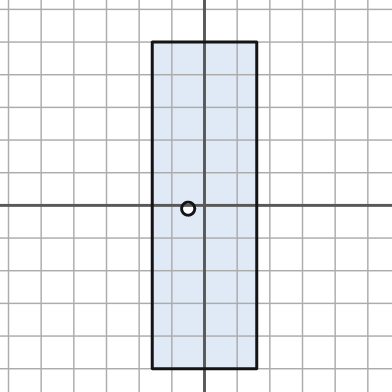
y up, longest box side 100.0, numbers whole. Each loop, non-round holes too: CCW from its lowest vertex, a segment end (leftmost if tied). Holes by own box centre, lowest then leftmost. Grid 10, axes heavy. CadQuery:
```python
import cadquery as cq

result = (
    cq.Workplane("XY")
    .moveTo(-16.0, -50.0)
    .lineTo(16.0, -50.0)
    .lineTo(16.0, 50.0)
    .lineTo(-16.0, 50.0)
    .close()
    .moveTo(-5.0, -1.0)
    .circle(2.0)
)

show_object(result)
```